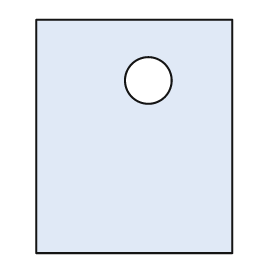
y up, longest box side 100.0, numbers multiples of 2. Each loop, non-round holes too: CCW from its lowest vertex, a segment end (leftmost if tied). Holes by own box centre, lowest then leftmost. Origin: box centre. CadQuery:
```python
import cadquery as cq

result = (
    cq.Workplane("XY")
    .moveTo(-42.0, -50.0)
    .lineTo(42.0, -50.0)
    .lineTo(42.0, 50.0)
    .lineTo(-42.0, 50.0)
    .close()
    .moveTo(6.0, 24.0)
    .circle(10.0)
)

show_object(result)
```